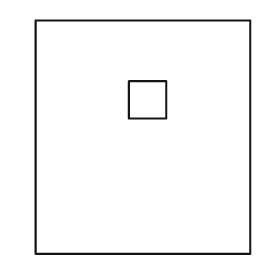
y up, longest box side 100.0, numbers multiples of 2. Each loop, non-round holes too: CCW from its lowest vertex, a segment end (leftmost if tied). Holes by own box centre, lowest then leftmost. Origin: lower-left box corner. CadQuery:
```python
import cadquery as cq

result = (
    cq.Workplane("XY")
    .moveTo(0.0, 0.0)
    .lineTo(92.0, 0.0)
    .lineTo(92.0, 100.0)
    .lineTo(0.0, 100.0)
    .close()
    .moveTo(40.0, 58.0)
    .lineTo(56.0, 58.0)
    .lineTo(56.0, 74.0)
    .lineTo(40.0, 74.0)
    .close()
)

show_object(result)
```